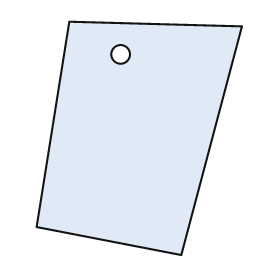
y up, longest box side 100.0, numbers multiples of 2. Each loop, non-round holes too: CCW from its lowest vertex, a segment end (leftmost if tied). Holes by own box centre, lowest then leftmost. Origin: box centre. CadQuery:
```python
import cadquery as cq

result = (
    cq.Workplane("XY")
    .moveTo(18.0, -50.0)
    .lineTo(44.0, 48.0)
    .lineTo(-30.0, 50.0)
    .lineTo(-44.0, -38.0)
    .close()
    .moveTo(-8.0, 36.0)
    .circle(4.0)
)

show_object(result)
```